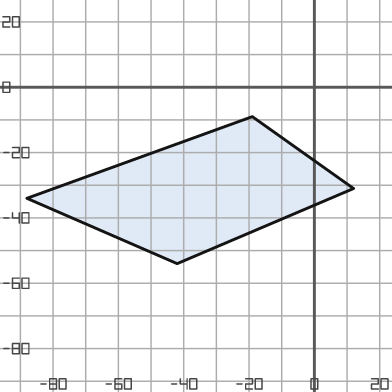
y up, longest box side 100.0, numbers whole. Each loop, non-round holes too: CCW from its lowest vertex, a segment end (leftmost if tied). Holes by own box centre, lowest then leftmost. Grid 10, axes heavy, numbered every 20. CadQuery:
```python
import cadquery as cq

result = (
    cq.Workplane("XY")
    .moveTo(-42.0, -54.0)
    .lineTo(12.0, -31.0)
    .lineTo(-19.0, -9.0)
    .lineTo(-88.0, -34.0)
    .close()
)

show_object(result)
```